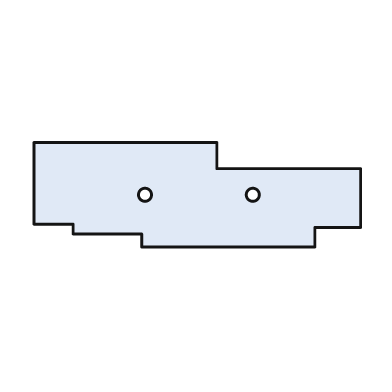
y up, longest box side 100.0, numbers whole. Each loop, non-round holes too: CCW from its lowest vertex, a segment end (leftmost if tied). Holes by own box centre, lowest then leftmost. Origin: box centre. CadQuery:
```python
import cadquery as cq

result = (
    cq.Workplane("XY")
    .moveTo(-17.0, -16.0)
    .lineTo(36.0, -16.0)
    .lineTo(36.0, -10.0)
    .lineTo(50.0, -10.0)
    .lineTo(50.0, 8.0)
    .lineTo(6.0, 8.0)
    .lineTo(6.0, 16.0)
    .lineTo(-50.0, 16.0)
    .lineTo(-50.0, -9.0)
    .lineTo(-38.0, -9.0)
    .lineTo(-38.0, -12.0)
    .lineTo(-17.0, -12.0)
    .close()
    .moveTo(-16.0, 0.0)
    .circle(2.0)
    .moveTo(17.0, 0.0)
    .circle(2.0)
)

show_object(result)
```